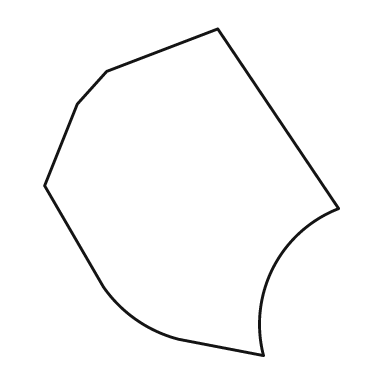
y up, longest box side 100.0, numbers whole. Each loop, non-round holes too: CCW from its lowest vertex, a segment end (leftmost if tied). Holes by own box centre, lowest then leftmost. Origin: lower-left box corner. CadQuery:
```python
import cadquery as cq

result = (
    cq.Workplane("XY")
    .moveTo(67.0, 0.0)
    .threePointArc((70.0, 27.0), (90.0, 45.0))
    .lineTo(53.0, 100.0)
    .lineTo(19.0, 87.0)
    .lineTo(10.0, 77.0)
    .lineTo(0.0, 52.0)
    .lineTo(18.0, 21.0)
    .threePointArc((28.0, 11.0), (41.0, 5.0))
    .close()
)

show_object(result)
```